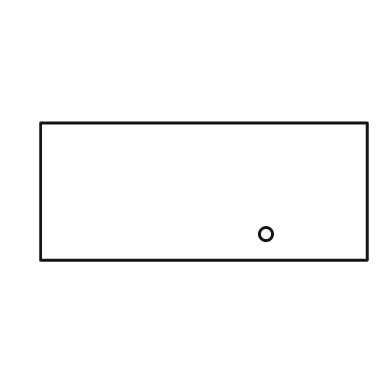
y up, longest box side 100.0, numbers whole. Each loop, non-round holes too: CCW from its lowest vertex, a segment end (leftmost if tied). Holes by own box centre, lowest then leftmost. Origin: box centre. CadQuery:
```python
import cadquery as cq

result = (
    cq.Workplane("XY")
    .moveTo(-50.0, -21.0)
    .lineTo(50.0, -21.0)
    .lineTo(50.0, 21.0)
    .lineTo(-50.0, 21.0)
    .close()
    .moveTo(19.0, -13.0)
    .circle(2.0)
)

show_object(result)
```